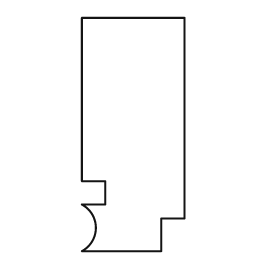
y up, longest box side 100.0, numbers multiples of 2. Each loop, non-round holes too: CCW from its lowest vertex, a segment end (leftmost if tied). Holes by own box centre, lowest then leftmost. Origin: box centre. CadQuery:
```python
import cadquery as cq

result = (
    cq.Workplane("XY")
    .moveTo(-22.0, -50.0)
    .lineTo(12.0, -50.0)
    .lineTo(12.0, -36.0)
    .lineTo(22.0, -36.0)
    .lineTo(22.0, 50.0)
    .lineTo(-22.0, 50.0)
    .lineTo(-22.0, -20.0)
    .lineTo(-12.0, -20.0)
    .lineTo(-12.0, -30.0)
    .lineTo(-22.0, -30.0)
    .threePointArc((-16.0, -40.0), (-22.0, -50.0))
    .close()
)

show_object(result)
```